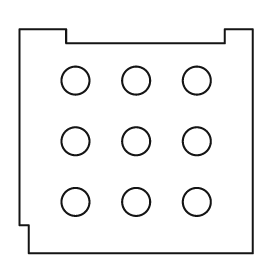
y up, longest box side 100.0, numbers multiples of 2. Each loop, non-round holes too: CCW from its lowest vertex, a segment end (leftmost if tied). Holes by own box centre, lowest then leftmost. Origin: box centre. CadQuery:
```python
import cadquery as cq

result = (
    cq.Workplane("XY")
    .moveTo(-46.0, -48.0)
    .lineTo(50.0, -48.0)
    .lineTo(50.0, 48.0)
    .lineTo(38.0, 48.0)
    .lineTo(38.0, 42.0)
    .lineTo(-30.0, 42.0)
    .lineTo(-30.0, 48.0)
    .lineTo(-50.0, 48.0)
    .lineTo(-50.0, -36.0)
    .lineTo(-46.0, -36.0)
    .close()
    .moveTo(-26.0, -26.0)
    .circle(6.0)
    .moveTo(0.0, -26.0)
    .circle(6.0)
    .moveTo(26.0, -26.0)
    .circle(6.0)
    .moveTo(-26.0, 0.0)
    .circle(6.0)
    .moveTo(0.0, 0.0)
    .circle(6.0)
    .moveTo(26.0, 0.0)
    .circle(6.0)
    .moveTo(-26.0, 26.0)
    .circle(6.0)
    .moveTo(0.0, 26.0)
    .circle(6.0)
    .moveTo(26.0, 26.0)
    .circle(6.0)
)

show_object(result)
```